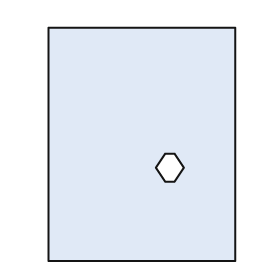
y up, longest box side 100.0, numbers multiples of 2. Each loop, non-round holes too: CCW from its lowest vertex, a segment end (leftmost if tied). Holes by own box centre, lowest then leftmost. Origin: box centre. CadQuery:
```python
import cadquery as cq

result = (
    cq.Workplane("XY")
    .moveTo(-40.0, -50.0)
    .lineTo(40.0, -50.0)
    .lineTo(40.0, 50.0)
    .lineTo(-40.0, 50.0)
    .close()
    .moveTo(10.0, -16.0)
    .lineTo(14.0, -16.0)
    .lineTo(18.0, -10.0)
    .lineTo(14.0, -4.0)
    .lineTo(10.0, -4.0)
    .lineTo(6.0, -10.0)
    .close()
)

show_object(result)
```